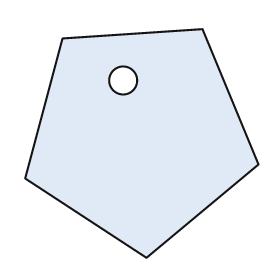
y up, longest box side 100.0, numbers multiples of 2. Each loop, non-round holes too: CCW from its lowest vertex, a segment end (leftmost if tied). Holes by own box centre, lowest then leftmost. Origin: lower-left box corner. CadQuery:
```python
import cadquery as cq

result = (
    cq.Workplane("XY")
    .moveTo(52.0, 0.0)
    .lineTo(100.0, 40.0)
    .lineTo(76.0, 98.0)
    .lineTo(16.0, 94.0)
    .lineTo(0.0, 34.0)
    .close()
    .moveTo(42.0, 76.0)
    .circle(6.0)
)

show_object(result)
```